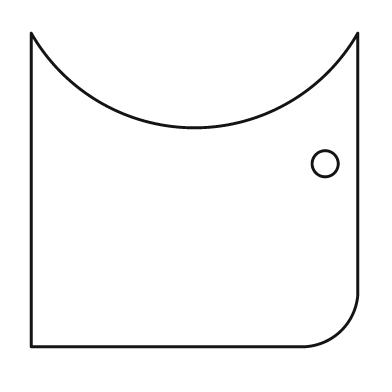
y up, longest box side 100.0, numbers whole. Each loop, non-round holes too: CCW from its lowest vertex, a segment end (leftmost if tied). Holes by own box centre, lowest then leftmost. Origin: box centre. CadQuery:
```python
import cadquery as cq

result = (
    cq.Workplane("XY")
    .moveTo(-50.0, -48.0)
    .lineTo(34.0, -48.0)
    .threePointArc((45.0, -43.0), (50.0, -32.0))
    .lineTo(50.0, 48.0)
    .threePointArc((0.0, 19.0), (-50.0, 48.0))
    .close()
    .moveTo(40.0, 8.0)
    .circle(4.0)
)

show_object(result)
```